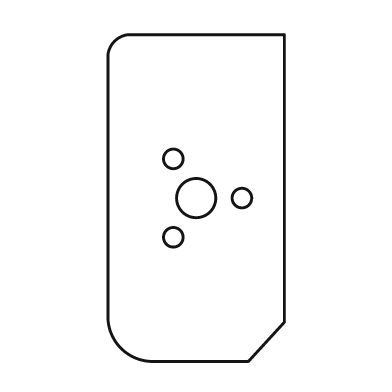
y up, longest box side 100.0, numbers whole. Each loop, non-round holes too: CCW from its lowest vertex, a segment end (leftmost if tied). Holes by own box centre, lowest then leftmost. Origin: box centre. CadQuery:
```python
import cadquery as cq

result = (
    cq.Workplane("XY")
    .moveTo(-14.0, -50.0)
    .lineTo(16.0, -50.0)
    .lineTo(27.0, -38.0)
    .lineTo(27.0, 50.0)
    .lineTo(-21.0, 50.0)
    .threePointArc((-25.0, 48.0), (-27.0, 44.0))
    .lineTo(-27.0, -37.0)
    .threePointArc((-23.0, -46.0), (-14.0, -50.0))
    .close()
    .moveTo(-7.0, -12.0)
    .circle(3.0)
    .moveTo(0.0, 0.0)
    .circle(6.0)
    .moveTo(14.0, 0.0)
    .circle(3.0)
    .moveTo(-7.0, 12.0)
    .circle(3.0)
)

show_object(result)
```